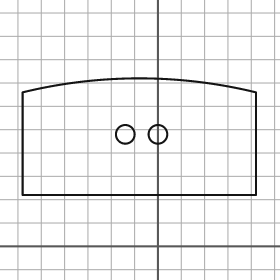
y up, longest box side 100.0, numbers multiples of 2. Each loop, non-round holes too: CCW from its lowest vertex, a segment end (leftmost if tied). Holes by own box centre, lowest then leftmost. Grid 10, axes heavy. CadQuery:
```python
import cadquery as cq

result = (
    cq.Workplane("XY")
    .moveTo(-58.0, 22.0)
    .lineTo(42.0, 22.0)
    .lineTo(42.0, 66.0)
    .threePointArc((-8.0, 72.0), (-58.0, 66.0))
    .close()
    .moveTo(-14.0, 48.0)
    .circle(4.0)
    .moveTo(0.0, 48.0)
    .circle(4.0)
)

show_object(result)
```